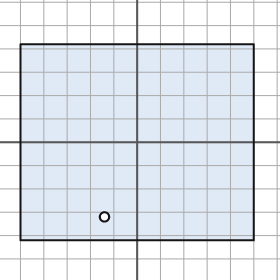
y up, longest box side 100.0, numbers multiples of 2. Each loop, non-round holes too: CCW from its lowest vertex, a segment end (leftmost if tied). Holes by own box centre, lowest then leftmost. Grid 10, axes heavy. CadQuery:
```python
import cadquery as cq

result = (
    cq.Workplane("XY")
    .moveTo(-50.0, -42.0)
    .lineTo(50.0, -42.0)
    .lineTo(50.0, 42.0)
    .lineTo(-50.0, 42.0)
    .close()
    .moveTo(-14.0, -32.0)
    .circle(2.0)
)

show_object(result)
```